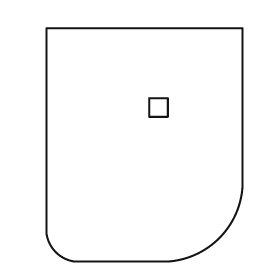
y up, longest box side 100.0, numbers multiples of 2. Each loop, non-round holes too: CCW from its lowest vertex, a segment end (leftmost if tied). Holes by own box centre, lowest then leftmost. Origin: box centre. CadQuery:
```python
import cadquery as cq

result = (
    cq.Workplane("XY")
    .moveTo(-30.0, -50.0)
    .lineTo(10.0, -50.0)
    .threePointArc((32.0, -40.0), (42.0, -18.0))
    .lineTo(42.0, 50.0)
    .lineTo(-42.0, 50.0)
    .lineTo(-42.0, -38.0)
    .threePointArc((-38.0, -46.0), (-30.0, -50.0))
    .close()
    .moveTo(2.0, 12.0)
    .lineTo(10.0, 12.0)
    .lineTo(10.0, 20.0)
    .lineTo(2.0, 20.0)
    .close()
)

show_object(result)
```